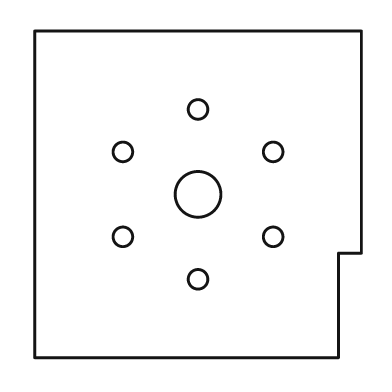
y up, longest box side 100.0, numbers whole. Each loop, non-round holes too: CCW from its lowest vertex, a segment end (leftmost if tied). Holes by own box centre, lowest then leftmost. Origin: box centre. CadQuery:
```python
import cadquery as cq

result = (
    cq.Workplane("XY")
    .moveTo(-50.0, -50.0)
    .lineTo(43.0, -50.0)
    .lineTo(43.0, -18.0)
    .lineTo(50.0, -18.0)
    .lineTo(50.0, 50.0)
    .lineTo(-50.0, 50.0)
    .close()
    .moveTo(0.0, -26.0)
    .circle(3.0)
    .moveTo(-23.0, -13.0)
    .circle(3.0)
    .moveTo(23.0, -13.0)
    .circle(3.0)
    .moveTo(0.0, 0.0)
    .circle(7.0)
    .moveTo(-23.0, 13.0)
    .circle(3.0)
    .moveTo(23.0, 13.0)
    .circle(3.0)
    .moveTo(0.0, 26.0)
    .circle(3.0)
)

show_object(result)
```